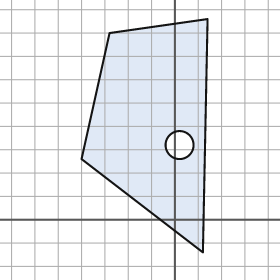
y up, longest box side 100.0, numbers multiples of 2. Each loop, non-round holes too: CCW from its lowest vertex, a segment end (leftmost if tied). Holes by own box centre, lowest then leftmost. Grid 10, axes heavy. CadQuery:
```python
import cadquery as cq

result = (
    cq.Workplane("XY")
    .moveTo(12.0, -14.0)
    .lineTo(14.0, 86.0)
    .lineTo(-28.0, 80.0)
    .lineTo(-40.0, 26.0)
    .close()
    .moveTo(2.0, 32.0)
    .circle(6.0)
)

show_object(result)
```